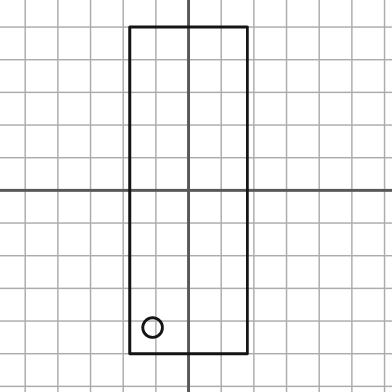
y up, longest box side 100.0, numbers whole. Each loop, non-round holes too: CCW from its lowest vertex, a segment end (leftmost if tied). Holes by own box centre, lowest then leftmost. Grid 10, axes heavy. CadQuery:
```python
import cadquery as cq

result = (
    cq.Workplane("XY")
    .moveTo(-18.0, -50.0)
    .lineTo(18.0, -50.0)
    .lineTo(18.0, 50.0)
    .lineTo(-18.0, 50.0)
    .close()
    .moveTo(-11.0, -42.0)
    .circle(3.0)
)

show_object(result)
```